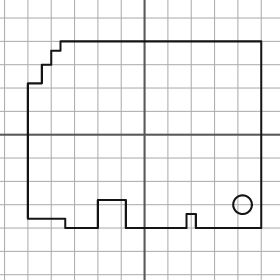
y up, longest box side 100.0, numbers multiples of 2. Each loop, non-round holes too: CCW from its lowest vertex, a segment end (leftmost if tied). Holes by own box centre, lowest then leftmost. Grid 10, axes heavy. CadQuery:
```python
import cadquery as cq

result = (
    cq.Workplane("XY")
    .moveTo(-34.0, -40.0)
    .lineTo(-20.0, -40.0)
    .lineTo(-20.0, -28.0)
    .lineTo(-8.0, -28.0)
    .lineTo(-8.0, -40.0)
    .lineTo(18.0, -40.0)
    .lineTo(18.0, -34.0)
    .lineTo(22.0, -34.0)
    .lineTo(22.0, -40.0)
    .lineTo(50.0, -40.0)
    .lineTo(50.0, 40.0)
    .lineTo(-36.0, 40.0)
    .lineTo(-36.0, 36.0)
    .lineTo(-40.0, 36.0)
    .lineTo(-40.0, 30.0)
    .lineTo(-44.0, 30.0)
    .lineTo(-44.0, 22.0)
    .lineTo(-50.0, 22.0)
    .lineTo(-50.0, -36.0)
    .lineTo(-34.0, -36.0)
    .close()
    .moveTo(42.0, -30.0)
    .circle(4.0)
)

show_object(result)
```